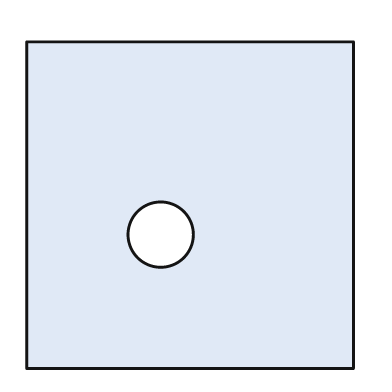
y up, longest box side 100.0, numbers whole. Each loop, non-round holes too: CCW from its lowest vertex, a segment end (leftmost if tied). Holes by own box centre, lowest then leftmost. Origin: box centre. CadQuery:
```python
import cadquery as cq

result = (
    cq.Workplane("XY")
    .moveTo(-50.0, -50.0)
    .lineTo(50.0, -50.0)
    .lineTo(50.0, 50.0)
    .lineTo(-50.0, 50.0)
    .close()
    .moveTo(-9.0, -9.0)
    .circle(10.0)
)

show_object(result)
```